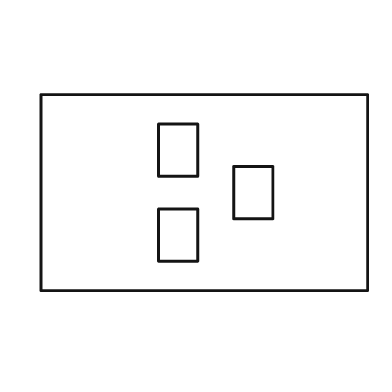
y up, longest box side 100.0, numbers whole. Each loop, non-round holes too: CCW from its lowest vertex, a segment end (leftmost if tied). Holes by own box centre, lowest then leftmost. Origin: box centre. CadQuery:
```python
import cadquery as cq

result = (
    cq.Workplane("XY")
    .moveTo(-50.0, -30.0)
    .lineTo(50.0, -30.0)
    .lineTo(50.0, 30.0)
    .lineTo(-50.0, 30.0)
    .close()
    .moveTo(-14.0, -21.0)
    .lineTo(-2.0, -21.0)
    .lineTo(-2.0, -5.0)
    .lineTo(-14.0, -5.0)
    .close()
    .moveTo(9.0, -8.0)
    .lineTo(21.0, -8.0)
    .lineTo(21.0, 8.0)
    .lineTo(9.0, 8.0)
    .close()
    .moveTo(-14.0, 5.0)
    .lineTo(-2.0, 5.0)
    .lineTo(-2.0, 21.0)
    .lineTo(-14.0, 21.0)
    .close()
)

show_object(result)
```